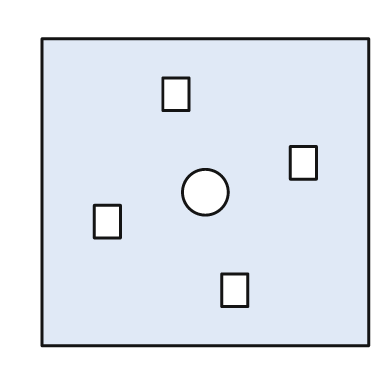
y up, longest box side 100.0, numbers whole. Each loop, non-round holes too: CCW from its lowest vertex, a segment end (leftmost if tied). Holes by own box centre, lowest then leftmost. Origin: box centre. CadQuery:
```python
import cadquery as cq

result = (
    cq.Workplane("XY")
    .moveTo(-50.0, -47.0)
    .lineTo(50.0, -47.0)
    .lineTo(50.0, 47.0)
    .lineTo(-50.0, 47.0)
    .close()
    .moveTo(5.0, -35.0)
    .lineTo(13.0, -35.0)
    .lineTo(13.0, -25.0)
    .lineTo(5.0, -25.0)
    .close()
    .moveTo(-34.0, -14.0)
    .lineTo(-26.0, -14.0)
    .lineTo(-26.0, -4.0)
    .lineTo(-34.0, -4.0)
    .close()
    .moveTo(0.0, 0.0)
    .circle(7.0)
    .moveTo(26.0, 4.0)
    .lineTo(34.0, 4.0)
    .lineTo(34.0, 14.0)
    .lineTo(26.0, 14.0)
    .close()
    .moveTo(-13.0, 25.0)
    .lineTo(-5.0, 25.0)
    .lineTo(-5.0, 35.0)
    .lineTo(-13.0, 35.0)
    .close()
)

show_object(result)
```